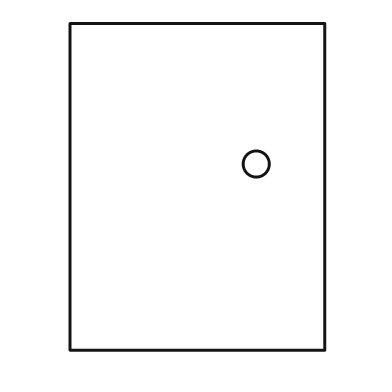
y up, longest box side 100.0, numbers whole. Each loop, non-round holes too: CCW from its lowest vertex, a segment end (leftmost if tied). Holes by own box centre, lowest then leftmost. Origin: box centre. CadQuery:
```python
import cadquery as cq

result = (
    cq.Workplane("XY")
    .moveTo(-39.0, -50.0)
    .lineTo(39.0, -50.0)
    .lineTo(39.0, 50.0)
    .lineTo(-39.0, 50.0)
    .close()
    .moveTo(18.0, 7.0)
    .circle(4.0)
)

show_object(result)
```